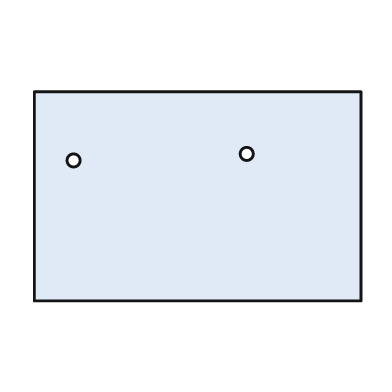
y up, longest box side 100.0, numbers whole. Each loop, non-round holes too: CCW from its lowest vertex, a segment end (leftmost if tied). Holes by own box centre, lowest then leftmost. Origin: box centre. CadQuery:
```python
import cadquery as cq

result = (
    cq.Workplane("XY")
    .moveTo(-50.0, -32.0)
    .lineTo(50.0, -32.0)
    .lineTo(50.0, 32.0)
    .lineTo(-50.0, 32.0)
    .close()
    .moveTo(-38.0, 11.0)
    .circle(2.0)
    .moveTo(15.0, 13.0)
    .circle(2.0)
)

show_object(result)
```